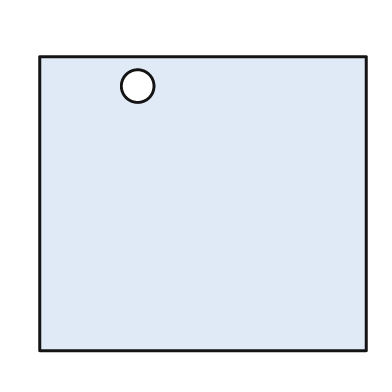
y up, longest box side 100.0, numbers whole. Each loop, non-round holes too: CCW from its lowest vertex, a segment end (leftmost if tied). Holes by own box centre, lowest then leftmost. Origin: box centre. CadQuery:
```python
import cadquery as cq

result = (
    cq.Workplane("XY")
    .moveTo(-50.0, -45.0)
    .lineTo(50.0, -45.0)
    .lineTo(50.0, 45.0)
    .lineTo(-50.0, 45.0)
    .close()
    .moveTo(-20.0, 36.0)
    .circle(5.0)
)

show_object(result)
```